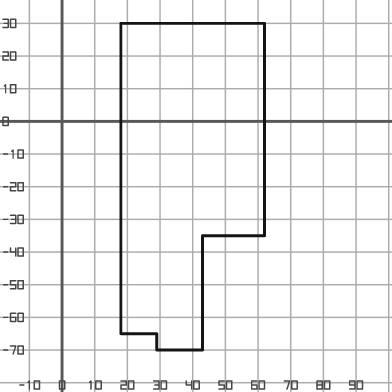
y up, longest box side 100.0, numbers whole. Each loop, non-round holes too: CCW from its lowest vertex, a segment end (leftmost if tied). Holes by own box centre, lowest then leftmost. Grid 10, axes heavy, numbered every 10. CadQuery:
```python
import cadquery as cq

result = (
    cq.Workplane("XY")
    .moveTo(29.0, -70.0)
    .lineTo(43.0, -70.0)
    .lineTo(43.0, -35.0)
    .lineTo(62.0, -35.0)
    .lineTo(62.0, 30.0)
    .lineTo(18.0, 30.0)
    .lineTo(18.0, -65.0)
    .lineTo(29.0, -65.0)
    .close()
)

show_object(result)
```